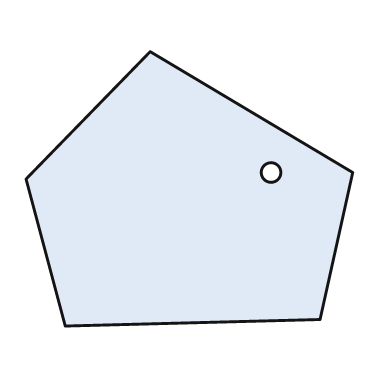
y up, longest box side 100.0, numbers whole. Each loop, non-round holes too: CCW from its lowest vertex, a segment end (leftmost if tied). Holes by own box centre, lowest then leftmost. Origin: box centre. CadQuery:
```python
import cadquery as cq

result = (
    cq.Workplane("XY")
    .moveTo(-38.0, -42.0)
    .lineTo(40.0, -40.0)
    .lineTo(50.0, 5.0)
    .lineTo(-12.0, 42.0)
    .lineTo(-50.0, 3.0)
    .close()
    .moveTo(25.0, 5.0)
    .circle(3.0)
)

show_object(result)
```